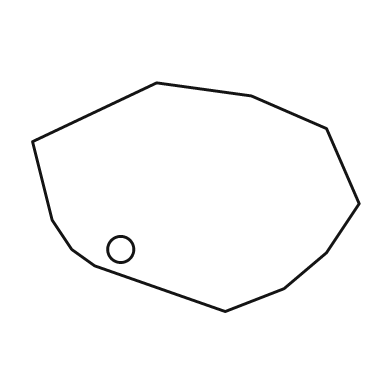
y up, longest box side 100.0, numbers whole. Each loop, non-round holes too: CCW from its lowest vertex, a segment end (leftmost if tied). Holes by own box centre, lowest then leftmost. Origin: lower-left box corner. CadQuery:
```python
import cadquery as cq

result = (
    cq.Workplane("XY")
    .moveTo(59.0, 0.0)
    .lineTo(77.0, 7.0)
    .lineTo(90.0, 18.0)
    .lineTo(100.0, 33.0)
    .lineTo(90.0, 56.0)
    .lineTo(67.0, 66.0)
    .lineTo(38.0, 70.0)
    .lineTo(0.0, 52.0)
    .lineTo(6.0, 28.0)
    .lineTo(12.0, 19.0)
    .lineTo(19.0, 14.0)
    .close()
    .moveTo(27.0, 19.0)
    .circle(4.0)
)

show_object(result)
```